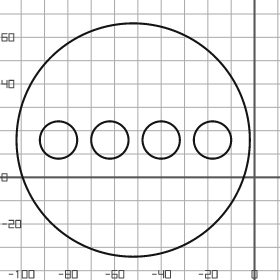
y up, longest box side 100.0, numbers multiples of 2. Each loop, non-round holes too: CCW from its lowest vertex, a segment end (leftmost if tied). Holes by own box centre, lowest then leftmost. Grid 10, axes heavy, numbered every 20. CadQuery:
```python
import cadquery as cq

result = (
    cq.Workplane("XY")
    .moveTo(-52.0, 16.0)
    .circle(50.0)
    .moveTo(-84.0, 16.0)
    .circle(8.0)
    .moveTo(-62.0, 16.0)
    .circle(8.0)
    .moveTo(-40.0, 16.0)
    .circle(8.0)
    .moveTo(-18.0, 16.0)
    .circle(8.0)
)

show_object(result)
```